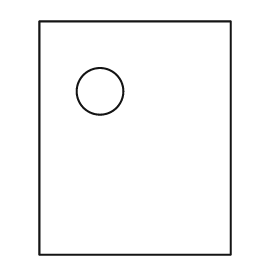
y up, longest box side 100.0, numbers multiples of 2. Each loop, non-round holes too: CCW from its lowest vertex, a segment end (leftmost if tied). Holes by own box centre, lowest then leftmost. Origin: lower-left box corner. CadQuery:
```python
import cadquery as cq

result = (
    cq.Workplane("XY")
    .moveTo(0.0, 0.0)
    .lineTo(82.0, 0.0)
    .lineTo(82.0, 100.0)
    .lineTo(0.0, 100.0)
    .close()
    .moveTo(26.0, 70.0)
    .circle(10.0)
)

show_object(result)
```